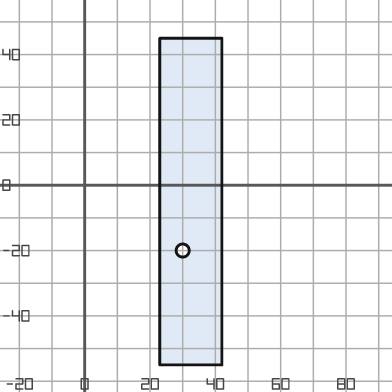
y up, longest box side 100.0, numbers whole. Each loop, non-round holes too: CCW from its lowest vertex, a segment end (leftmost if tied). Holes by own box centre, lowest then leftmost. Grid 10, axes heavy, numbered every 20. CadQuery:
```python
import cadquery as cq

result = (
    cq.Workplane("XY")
    .moveTo(23.0, -55.0)
    .lineTo(42.0, -55.0)
    .lineTo(42.0, 45.0)
    .lineTo(23.0, 45.0)
    .close()
    .moveTo(30.0, -20.0)
    .circle(2.0)
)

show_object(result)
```